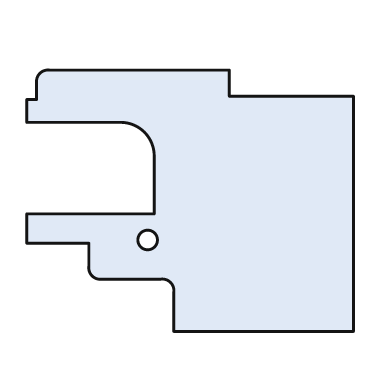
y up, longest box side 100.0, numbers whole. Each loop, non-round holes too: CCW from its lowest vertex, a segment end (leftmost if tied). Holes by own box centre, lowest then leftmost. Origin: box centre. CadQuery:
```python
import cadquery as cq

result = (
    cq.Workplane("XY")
    .moveTo(-5.0, -40.0)
    .lineTo(50.0, -40.0)
    .lineTo(50.0, 32.0)
    .lineTo(12.0, 32.0)
    .lineTo(12.0, 40.0)
    .lineTo(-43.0, 40.0)
    .threePointArc((-46.0, 39.0), (-47.0, 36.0))
    .lineTo(-47.0, 31.0)
    .lineTo(-50.0, 31.0)
    .lineTo(-50.0, 24.0)
    .lineTo(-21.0, 24.0)
    .threePointArc((-14.0, 21.0), (-11.0, 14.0))
    .lineTo(-11.0, -4.0)
    .lineTo(-50.0, -4.0)
    .lineTo(-50.0, -13.0)
    .lineTo(-31.0, -13.0)
    .lineTo(-31.0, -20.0)
    .threePointArc((-30.0, -23.0), (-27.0, -24.0))
    .lineTo(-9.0, -24.0)
    .threePointArc((-6.0, -25.0), (-5.0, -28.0))
    .close()
    .moveTo(-13.0, -12.0)
    .circle(3.0)
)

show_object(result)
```